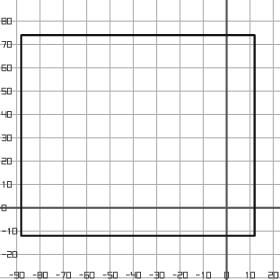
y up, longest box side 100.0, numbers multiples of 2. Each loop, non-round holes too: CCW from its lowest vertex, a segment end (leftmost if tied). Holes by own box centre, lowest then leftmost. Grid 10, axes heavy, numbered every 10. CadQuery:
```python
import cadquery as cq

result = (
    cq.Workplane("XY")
    .moveTo(-88.0, -12.0)
    .lineTo(12.0, -12.0)
    .lineTo(12.0, 74.0)
    .lineTo(-88.0, 74.0)
    .close()
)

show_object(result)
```